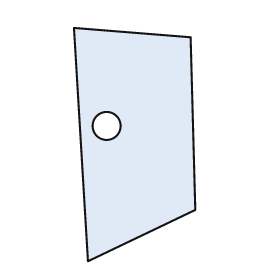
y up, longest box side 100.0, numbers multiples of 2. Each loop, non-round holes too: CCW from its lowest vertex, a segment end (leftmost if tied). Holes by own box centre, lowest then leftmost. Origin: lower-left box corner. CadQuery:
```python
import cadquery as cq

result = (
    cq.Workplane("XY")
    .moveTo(6.0, 0.0)
    .lineTo(52.0, 22.0)
    .lineTo(50.0, 96.0)
    .lineTo(0.0, 100.0)
    .close()
    .moveTo(14.0, 58.0)
    .circle(6.0)
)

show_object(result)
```